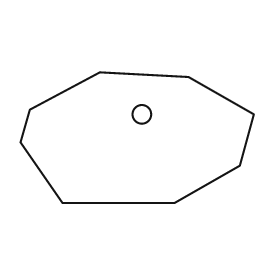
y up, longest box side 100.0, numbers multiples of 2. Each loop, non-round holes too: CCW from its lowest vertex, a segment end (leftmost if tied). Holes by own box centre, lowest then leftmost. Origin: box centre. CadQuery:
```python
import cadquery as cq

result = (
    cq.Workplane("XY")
    .moveTo(-32.0, -28.0)
    .lineTo(16.0, -28.0)
    .lineTo(44.0, -12.0)
    .lineTo(50.0, 10.0)
    .lineTo(22.0, 26.0)
    .lineTo(-16.0, 28.0)
    .lineTo(-46.0, 12.0)
    .lineTo(-50.0, -2.0)
    .close()
    .moveTo(2.0, 10.0)
    .circle(4.0)
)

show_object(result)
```